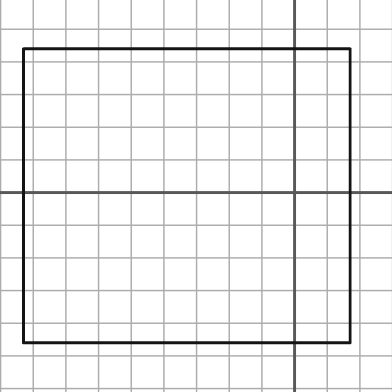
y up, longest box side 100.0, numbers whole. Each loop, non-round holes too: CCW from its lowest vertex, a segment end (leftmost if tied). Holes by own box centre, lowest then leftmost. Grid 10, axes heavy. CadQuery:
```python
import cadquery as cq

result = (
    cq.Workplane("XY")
    .moveTo(-83.0, -46.0)
    .lineTo(17.0, -46.0)
    .lineTo(17.0, 44.0)
    .lineTo(-83.0, 44.0)
    .close()
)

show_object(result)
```